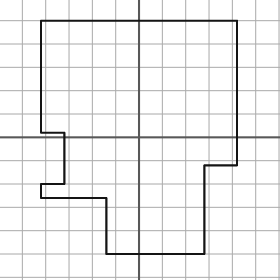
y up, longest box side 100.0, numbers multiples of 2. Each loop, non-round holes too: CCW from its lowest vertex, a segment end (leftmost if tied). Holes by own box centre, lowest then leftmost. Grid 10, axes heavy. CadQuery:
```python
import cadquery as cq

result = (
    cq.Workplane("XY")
    .moveTo(-14.0, -50.0)
    .lineTo(28.0, -50.0)
    .lineTo(28.0, -12.0)
    .lineTo(42.0, -12.0)
    .lineTo(42.0, 50.0)
    .lineTo(-42.0, 50.0)
    .lineTo(-42.0, 2.0)
    .lineTo(-32.0, 2.0)
    .lineTo(-32.0, -20.0)
    .lineTo(-42.0, -20.0)
    .lineTo(-42.0, -26.0)
    .lineTo(-14.0, -26.0)
    .close()
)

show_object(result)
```